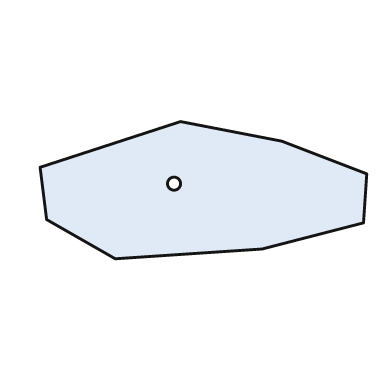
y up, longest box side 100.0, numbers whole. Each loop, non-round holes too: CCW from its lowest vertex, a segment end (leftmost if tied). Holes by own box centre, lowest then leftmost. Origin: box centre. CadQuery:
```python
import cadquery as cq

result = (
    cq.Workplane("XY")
    .moveTo(-27.0, -21.0)
    .lineTo(18.0, -18.0)
    .lineTo(49.0, -10.0)
    .lineTo(50.0, 5.0)
    .lineTo(24.0, 15.0)
    .lineTo(-7.0, 21.0)
    .lineTo(-50.0, 7.0)
    .lineTo(-48.0, -9.0)
    .close()
    .moveTo(-9.0, 2.0)
    .circle(2.0)
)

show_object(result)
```